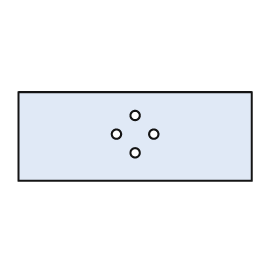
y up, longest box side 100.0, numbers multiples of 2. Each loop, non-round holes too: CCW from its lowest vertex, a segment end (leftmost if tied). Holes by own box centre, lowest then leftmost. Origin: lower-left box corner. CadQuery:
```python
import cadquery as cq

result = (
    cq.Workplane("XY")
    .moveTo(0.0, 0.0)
    .lineTo(100.0, 0.0)
    .lineTo(100.0, 38.0)
    .lineTo(0.0, 38.0)
    .close()
    .moveTo(50.0, 12.0)
    .circle(2.0)
    .moveTo(42.0, 20.0)
    .circle(2.0)
    .moveTo(58.0, 20.0)
    .circle(2.0)
    .moveTo(50.0, 28.0)
    .circle(2.0)
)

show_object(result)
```